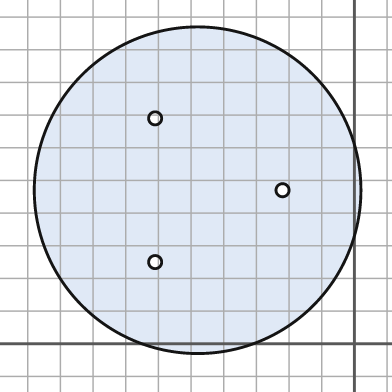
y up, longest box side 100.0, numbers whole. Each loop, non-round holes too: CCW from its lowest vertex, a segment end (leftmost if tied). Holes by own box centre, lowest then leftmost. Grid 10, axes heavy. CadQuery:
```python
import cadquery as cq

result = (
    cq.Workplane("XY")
    .moveTo(-48.0, 47.0)
    .circle(50.0)
    .moveTo(-61.0, 25.0)
    .circle(2.0)
    .moveTo(-22.0, 47.0)
    .circle(2.0)
    .moveTo(-61.0, 69.0)
    .circle(2.0)
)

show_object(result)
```